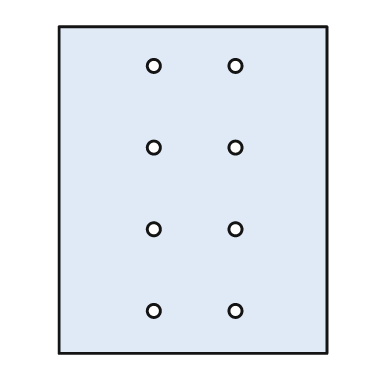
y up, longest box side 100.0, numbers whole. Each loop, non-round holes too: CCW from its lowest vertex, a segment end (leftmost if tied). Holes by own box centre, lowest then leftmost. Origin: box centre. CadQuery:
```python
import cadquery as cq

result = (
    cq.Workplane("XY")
    .moveTo(-41.0, -50.0)
    .lineTo(41.0, -50.0)
    .lineTo(41.0, 50.0)
    .lineTo(-41.0, 50.0)
    .close()
    .moveTo(-12.0, -37.0)
    .circle(2.0)
    .moveTo(13.0, -37.0)
    .circle(2.0)
    .moveTo(-12.0, -12.0)
    .circle(2.0)
    .moveTo(13.0, -12.0)
    .circle(2.0)
    .moveTo(-12.0, 13.0)
    .circle(2.0)
    .moveTo(13.0, 13.0)
    .circle(2.0)
    .moveTo(-12.0, 38.0)
    .circle(2.0)
    .moveTo(13.0, 38.0)
    .circle(2.0)
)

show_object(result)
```